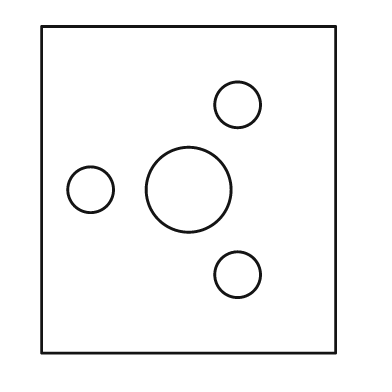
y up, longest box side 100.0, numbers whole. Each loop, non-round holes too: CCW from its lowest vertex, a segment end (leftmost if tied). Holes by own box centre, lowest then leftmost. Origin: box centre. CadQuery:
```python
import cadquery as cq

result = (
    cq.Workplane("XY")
    .moveTo(-45.0, -50.0)
    .lineTo(45.0, -50.0)
    .lineTo(45.0, 50.0)
    .lineTo(-45.0, 50.0)
    .close()
    .moveTo(15.0, -26.0)
    .circle(7.0)
    .moveTo(-30.0, 0.0)
    .circle(7.0)
    .moveTo(0.0, 0.0)
    .circle(13.0)
    .moveTo(15.0, 26.0)
    .circle(7.0)
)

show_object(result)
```